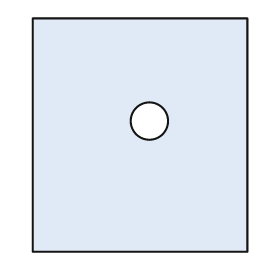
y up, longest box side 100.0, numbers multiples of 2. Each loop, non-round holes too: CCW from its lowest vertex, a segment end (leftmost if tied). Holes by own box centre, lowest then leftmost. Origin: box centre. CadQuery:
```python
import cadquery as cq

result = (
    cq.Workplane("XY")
    .moveTo(-46.0, -50.0)
    .lineTo(46.0, -50.0)
    .lineTo(46.0, 50.0)
    .lineTo(-46.0, 50.0)
    .close()
    .moveTo(4.0, 6.0)
    .circle(8.0)
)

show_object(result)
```